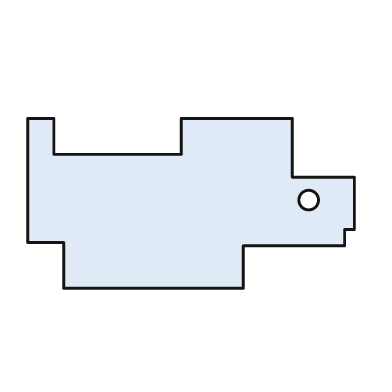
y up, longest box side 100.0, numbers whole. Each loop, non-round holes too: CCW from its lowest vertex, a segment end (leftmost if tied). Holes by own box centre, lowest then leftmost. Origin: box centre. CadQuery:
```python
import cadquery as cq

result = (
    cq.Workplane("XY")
    .moveTo(-39.0, -26.0)
    .lineTo(16.0, -26.0)
    .lineTo(16.0, -13.0)
    .lineTo(47.0, -13.0)
    .lineTo(47.0, -8.0)
    .lineTo(50.0, -8.0)
    .lineTo(50.0, 8.0)
    .lineTo(31.0, 8.0)
    .lineTo(31.0, 26.0)
    .lineTo(-3.0, 26.0)
    .lineTo(-3.0, 15.0)
    .lineTo(-42.0, 15.0)
    .lineTo(-42.0, 26.0)
    .lineTo(-50.0, 26.0)
    .lineTo(-50.0, -12.0)
    .lineTo(-39.0, -12.0)
    .close()
    .moveTo(36.0, 1.0)
    .circle(3.0)
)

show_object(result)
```